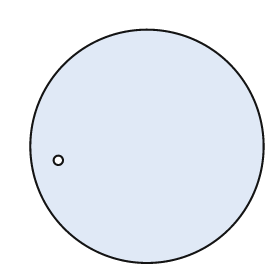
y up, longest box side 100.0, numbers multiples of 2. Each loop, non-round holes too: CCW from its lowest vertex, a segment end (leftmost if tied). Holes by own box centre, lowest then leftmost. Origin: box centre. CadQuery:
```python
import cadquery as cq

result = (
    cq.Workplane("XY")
    .moveTo(0.0, 0.0)
    .circle(50.0)
    .moveTo(-38.0, -6.0)
    .circle(2.0)
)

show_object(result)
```